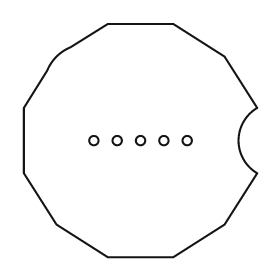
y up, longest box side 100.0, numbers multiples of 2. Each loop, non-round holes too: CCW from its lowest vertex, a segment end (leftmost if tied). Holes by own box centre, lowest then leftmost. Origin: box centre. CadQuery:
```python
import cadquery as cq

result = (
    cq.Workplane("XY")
    .moveTo(-14.0, -50.0)
    .lineTo(14.0, -50.0)
    .lineTo(36.0, -36.0)
    .lineTo(50.0, -14.0)
    .threePointArc((42.0, 0.0), (50.0, 14.0))
    .lineTo(36.0, 36.0)
    .lineTo(14.0, 50.0)
    .lineTo(-14.0, 50.0)
    .lineTo(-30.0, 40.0)
    .threePointArc((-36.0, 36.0), (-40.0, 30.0))
    .lineTo(-50.0, 14.0)
    .lineTo(-50.0, -14.0)
    .lineTo(-36.0, -36.0)
    .close()
    .moveTo(-20.0, 0.0)
    .circle(2.0)
    .moveTo(-10.0, 0.0)
    .circle(2.0)
    .moveTo(0.0, 0.0)
    .circle(2.0)
    .moveTo(10.0, 0.0)
    .circle(2.0)
    .moveTo(20.0, 0.0)
    .circle(2.0)
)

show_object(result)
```